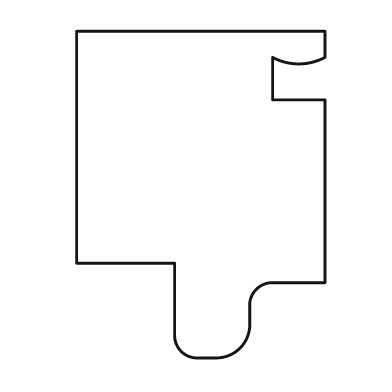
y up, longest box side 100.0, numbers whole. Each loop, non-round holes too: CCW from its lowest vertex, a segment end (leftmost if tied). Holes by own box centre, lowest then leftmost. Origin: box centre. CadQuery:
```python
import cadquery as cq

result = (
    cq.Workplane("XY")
    .moveTo(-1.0, -50.0)
    .lineTo(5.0, -50.0)
    .threePointArc((12.0, -47.0), (15.0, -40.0))
    .lineTo(15.0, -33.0)
    .threePointArc((17.0, -29.0), (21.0, -27.0))
    .lineTo(38.0, -27.0)
    .lineTo(38.0, 29.0)
    .lineTo(22.0, 29.0)
    .lineTo(22.0, 42.0)
    .threePointArc((30.0, 40.0), (38.0, 42.0))
    .lineTo(38.0, 50.0)
    .lineTo(-38.0, 50.0)
    .lineTo(-38.0, -21.0)
    .lineTo(-8.0, -21.0)
    .lineTo(-8.0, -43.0)
    .threePointArc((-6.0, -48.0), (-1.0, -50.0))
    .close()
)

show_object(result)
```